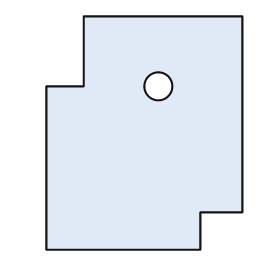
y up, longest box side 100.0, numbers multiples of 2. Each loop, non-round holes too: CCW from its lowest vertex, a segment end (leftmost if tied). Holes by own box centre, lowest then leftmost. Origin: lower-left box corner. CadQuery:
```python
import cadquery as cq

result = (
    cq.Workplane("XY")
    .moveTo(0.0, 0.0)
    .lineTo(66.0, 0.0)
    .lineTo(66.0, 16.0)
    .lineTo(84.0, 16.0)
    .lineTo(84.0, 100.0)
    .lineTo(16.0, 100.0)
    .lineTo(16.0, 70.0)
    .lineTo(0.0, 70.0)
    .close()
    .moveTo(48.0, 70.0)
    .circle(6.0)
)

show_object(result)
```